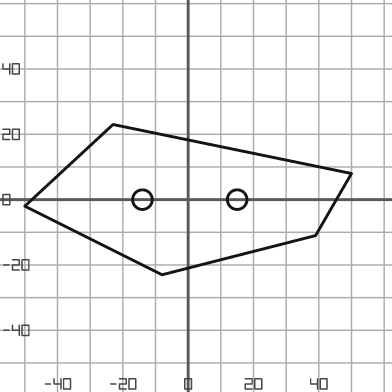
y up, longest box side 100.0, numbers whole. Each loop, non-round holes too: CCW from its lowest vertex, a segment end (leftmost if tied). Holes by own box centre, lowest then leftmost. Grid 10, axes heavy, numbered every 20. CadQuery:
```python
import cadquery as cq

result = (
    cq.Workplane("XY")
    .moveTo(-8.0, -23.0)
    .lineTo(39.0, -11.0)
    .lineTo(50.0, 8.0)
    .lineTo(-23.0, 23.0)
    .lineTo(-50.0, -2.0)
    .close()
    .moveTo(-14.0, 0.0)
    .circle(3.0)
    .moveTo(15.0, 0.0)
    .circle(3.0)
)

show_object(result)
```